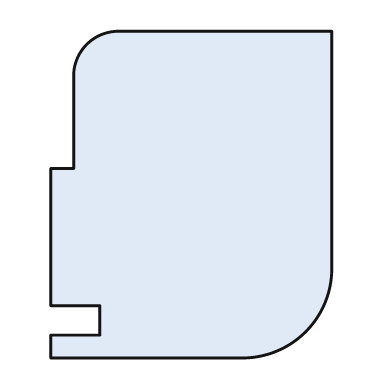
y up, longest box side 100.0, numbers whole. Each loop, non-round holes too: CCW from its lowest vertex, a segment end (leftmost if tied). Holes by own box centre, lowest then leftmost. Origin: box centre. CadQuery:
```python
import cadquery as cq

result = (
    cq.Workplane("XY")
    .moveTo(-43.0, -50.0)
    .lineTo(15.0, -50.0)
    .threePointArc((35.0, -42.0), (43.0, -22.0))
    .lineTo(43.0, 50.0)
    .lineTo(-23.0, 50.0)
    .threePointArc((-32.0, 46.0), (-36.0, 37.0))
    .lineTo(-36.0, 8.0)
    .lineTo(-43.0, 8.0)
    .lineTo(-43.0, -34.0)
    .lineTo(-28.0, -34.0)
    .lineTo(-28.0, -43.0)
    .lineTo(-43.0, -43.0)
    .close()
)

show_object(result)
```